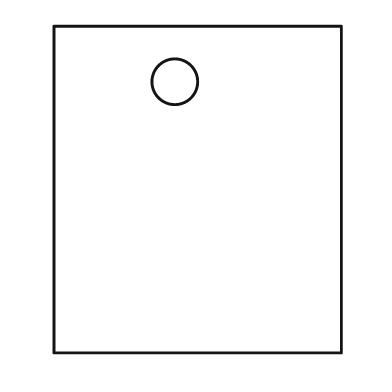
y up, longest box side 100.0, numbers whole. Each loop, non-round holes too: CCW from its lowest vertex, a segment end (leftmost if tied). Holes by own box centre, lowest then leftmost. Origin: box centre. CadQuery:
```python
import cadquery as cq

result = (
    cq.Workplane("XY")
    .moveTo(-44.0, -50.0)
    .lineTo(44.0, -50.0)
    .lineTo(44.0, 50.0)
    .lineTo(-44.0, 50.0)
    .close()
    .moveTo(-7.0, 33.0)
    .circle(7.0)
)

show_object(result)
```